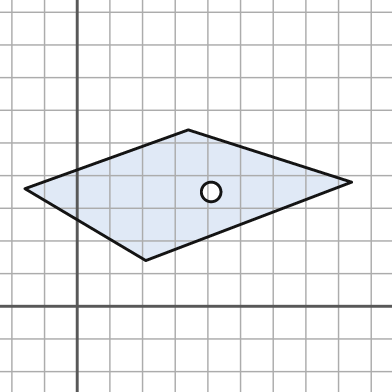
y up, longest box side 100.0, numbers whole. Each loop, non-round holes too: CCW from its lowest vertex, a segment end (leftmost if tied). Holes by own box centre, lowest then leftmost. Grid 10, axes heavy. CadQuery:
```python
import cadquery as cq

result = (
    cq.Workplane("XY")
    .moveTo(21.0, 14.0)
    .lineTo(84.0, 38.0)
    .lineTo(34.0, 54.0)
    .lineTo(-16.0, 36.0)
    .close()
    .moveTo(41.0, 35.0)
    .circle(3.0)
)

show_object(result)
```